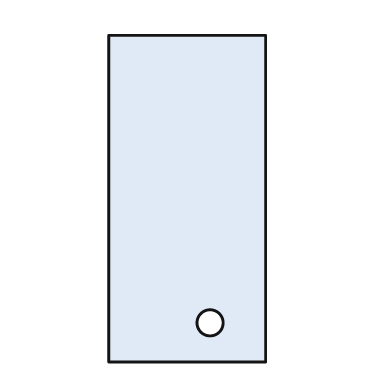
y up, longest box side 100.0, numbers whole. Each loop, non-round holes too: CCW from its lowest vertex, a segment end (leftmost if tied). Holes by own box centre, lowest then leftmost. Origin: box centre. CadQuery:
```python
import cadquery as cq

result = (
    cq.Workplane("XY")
    .moveTo(-24.0, -50.0)
    .lineTo(24.0, -50.0)
    .lineTo(24.0, 50.0)
    .lineTo(-24.0, 50.0)
    .close()
    .moveTo(7.0, -38.0)
    .circle(4.0)
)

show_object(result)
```